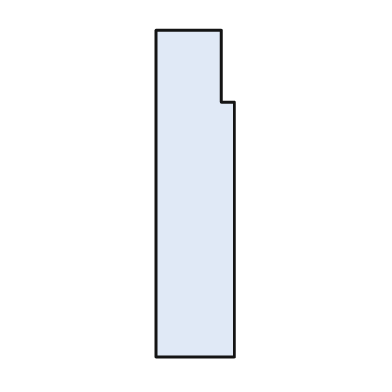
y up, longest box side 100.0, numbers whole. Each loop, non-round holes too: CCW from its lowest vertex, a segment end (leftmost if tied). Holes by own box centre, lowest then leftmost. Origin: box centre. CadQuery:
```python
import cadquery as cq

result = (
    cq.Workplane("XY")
    .moveTo(-12.0, -50.0)
    .lineTo(12.0, -50.0)
    .lineTo(12.0, 28.0)
    .lineTo(8.0, 28.0)
    .lineTo(8.0, 50.0)
    .lineTo(-12.0, 50.0)
    .close()
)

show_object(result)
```